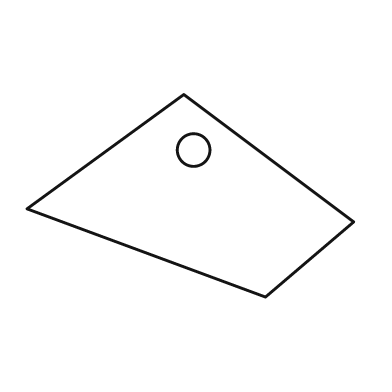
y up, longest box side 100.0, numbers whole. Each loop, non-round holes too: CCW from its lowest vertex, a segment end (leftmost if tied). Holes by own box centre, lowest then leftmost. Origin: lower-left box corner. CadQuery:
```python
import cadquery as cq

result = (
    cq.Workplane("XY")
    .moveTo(73.0, 0.0)
    .lineTo(100.0, 23.0)
    .lineTo(48.0, 62.0)
    .lineTo(0.0, 27.0)
    .close()
    .moveTo(51.0, 45.0)
    .circle(5.0)
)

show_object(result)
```